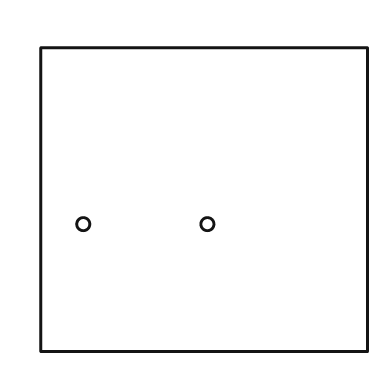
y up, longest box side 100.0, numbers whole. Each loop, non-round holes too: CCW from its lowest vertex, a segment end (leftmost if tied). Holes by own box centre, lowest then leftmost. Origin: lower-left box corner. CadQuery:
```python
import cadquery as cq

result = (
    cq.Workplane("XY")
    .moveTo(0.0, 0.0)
    .lineTo(100.0, 0.0)
    .lineTo(100.0, 93.0)
    .lineTo(0.0, 93.0)
    .close()
    .moveTo(13.0, 39.0)
    .circle(2.0)
    .moveTo(51.0, 39.0)
    .circle(2.0)
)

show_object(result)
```